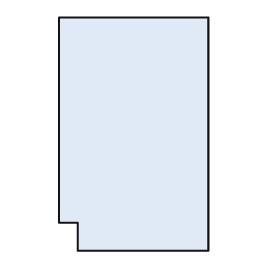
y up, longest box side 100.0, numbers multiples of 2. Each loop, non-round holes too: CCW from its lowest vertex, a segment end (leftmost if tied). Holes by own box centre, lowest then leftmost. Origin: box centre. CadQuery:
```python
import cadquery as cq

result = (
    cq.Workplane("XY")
    .moveTo(-24.0, -50.0)
    .lineTo(32.0, -50.0)
    .lineTo(32.0, 50.0)
    .lineTo(-32.0, 50.0)
    .lineTo(-32.0, -38.0)
    .lineTo(-24.0, -38.0)
    .close()
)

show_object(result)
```